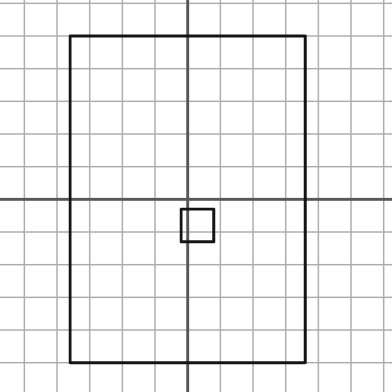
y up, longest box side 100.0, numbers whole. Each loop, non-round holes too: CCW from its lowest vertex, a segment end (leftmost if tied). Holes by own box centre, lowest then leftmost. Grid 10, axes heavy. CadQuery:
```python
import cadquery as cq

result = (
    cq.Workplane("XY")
    .moveTo(-36.0, -50.0)
    .lineTo(36.0, -50.0)
    .lineTo(36.0, 50.0)
    .lineTo(-36.0, 50.0)
    .close()
    .moveTo(-2.0, -13.0)
    .lineTo(8.0, -13.0)
    .lineTo(8.0, -3.0)
    .lineTo(-2.0, -3.0)
    .close()
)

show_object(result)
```